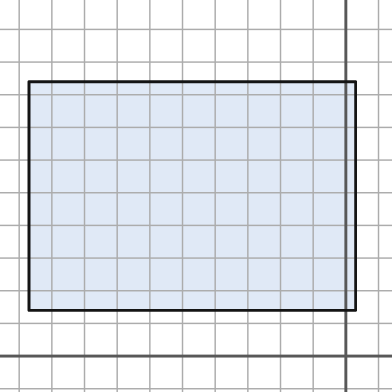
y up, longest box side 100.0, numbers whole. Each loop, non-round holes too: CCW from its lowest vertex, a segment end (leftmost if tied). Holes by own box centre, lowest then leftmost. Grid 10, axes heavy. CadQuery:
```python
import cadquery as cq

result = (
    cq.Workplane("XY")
    .moveTo(-97.0, 14.0)
    .lineTo(3.0, 14.0)
    .lineTo(3.0, 84.0)
    .lineTo(-97.0, 84.0)
    .close()
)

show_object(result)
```